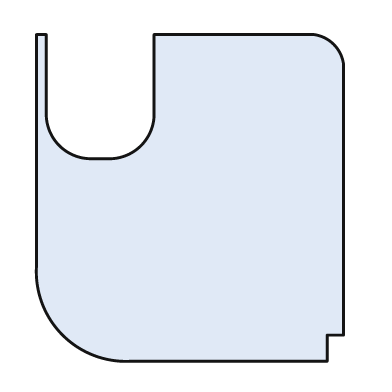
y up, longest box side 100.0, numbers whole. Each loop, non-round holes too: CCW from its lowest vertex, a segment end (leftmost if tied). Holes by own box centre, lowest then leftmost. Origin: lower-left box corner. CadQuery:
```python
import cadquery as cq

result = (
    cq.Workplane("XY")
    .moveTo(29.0, 0.0)
    .lineTo(89.0, 0.0)
    .lineTo(89.0, 8.0)
    .lineTo(94.0, 8.0)
    .lineTo(94.0, 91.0)
    .threePointArc((91.0, 97.0), (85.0, 100.0))
    .lineTo(36.0, 100.0)
    .lineTo(36.0, 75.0)
    .threePointArc((32.0, 66.0), (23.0, 62.0))
    .lineTo(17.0, 62.0)
    .threePointArc((7.0, 66.0), (3.0, 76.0))
    .lineTo(3.0, 100.0)
    .lineTo(0.0, 100.0)
    .lineTo(0.0, 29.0)
    .threePointArc((8.0, 8.0), (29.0, 0.0))
    .close()
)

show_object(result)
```